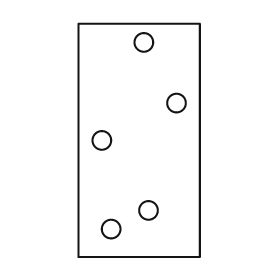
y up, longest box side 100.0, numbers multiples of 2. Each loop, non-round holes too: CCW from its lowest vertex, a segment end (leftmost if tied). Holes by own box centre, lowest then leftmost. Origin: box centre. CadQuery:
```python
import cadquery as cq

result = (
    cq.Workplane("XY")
    .moveTo(-26.0, -50.0)
    .lineTo(26.0, -50.0)
    .lineTo(26.0, 50.0)
    .lineTo(-26.0, 50.0)
    .close()
    .moveTo(-12.0, -38.0)
    .circle(4.0)
    .moveTo(4.0, -30.0)
    .circle(4.0)
    .moveTo(-16.0, 0.0)
    .circle(4.0)
    .moveTo(16.0, 16.0)
    .circle(4.0)
    .moveTo(2.0, 42.0)
    .circle(4.0)
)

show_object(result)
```